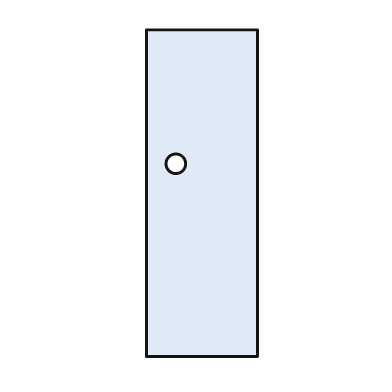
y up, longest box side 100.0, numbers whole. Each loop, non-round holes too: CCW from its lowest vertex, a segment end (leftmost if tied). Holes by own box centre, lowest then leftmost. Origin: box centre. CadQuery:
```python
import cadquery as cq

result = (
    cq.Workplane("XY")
    .moveTo(-17.0, -50.0)
    .lineTo(17.0, -50.0)
    .lineTo(17.0, 50.0)
    .lineTo(-17.0, 50.0)
    .close()
    .moveTo(-8.0, 9.0)
    .circle(3.0)
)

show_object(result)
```